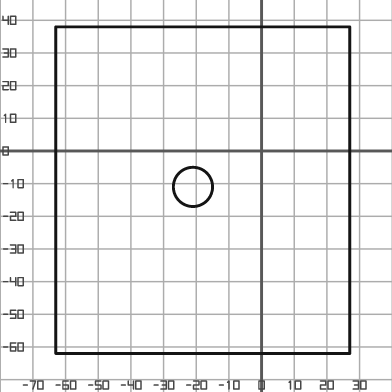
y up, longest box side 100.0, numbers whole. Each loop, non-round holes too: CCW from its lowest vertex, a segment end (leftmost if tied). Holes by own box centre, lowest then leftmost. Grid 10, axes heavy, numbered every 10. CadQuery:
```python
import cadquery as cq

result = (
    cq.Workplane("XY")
    .moveTo(-63.0, -62.0)
    .lineTo(27.0, -62.0)
    .lineTo(27.0, 38.0)
    .lineTo(-63.0, 38.0)
    .close()
    .moveTo(-21.0, -11.0)
    .circle(6.0)
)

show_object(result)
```